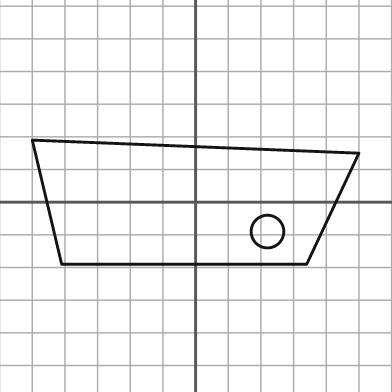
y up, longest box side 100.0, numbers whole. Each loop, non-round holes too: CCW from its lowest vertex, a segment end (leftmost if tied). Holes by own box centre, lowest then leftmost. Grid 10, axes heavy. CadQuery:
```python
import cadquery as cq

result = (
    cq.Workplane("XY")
    .moveTo(-41.0, -19.0)
    .lineTo(34.0, -19.0)
    .lineTo(50.0, 15.0)
    .lineTo(-50.0, 19.0)
    .close()
    .moveTo(22.0, -9.0)
    .circle(5.0)
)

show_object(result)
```